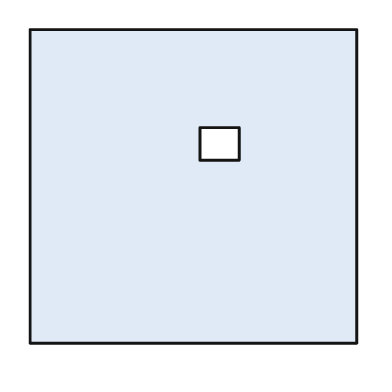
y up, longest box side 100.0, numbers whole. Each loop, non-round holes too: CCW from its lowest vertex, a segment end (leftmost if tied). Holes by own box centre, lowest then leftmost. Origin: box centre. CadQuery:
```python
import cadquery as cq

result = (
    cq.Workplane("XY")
    .moveTo(-50.0, -48.0)
    .lineTo(50.0, -48.0)
    .lineTo(50.0, 48.0)
    .lineTo(-50.0, 48.0)
    .close()
    .moveTo(2.0, 8.0)
    .lineTo(14.0, 8.0)
    .lineTo(14.0, 18.0)
    .lineTo(2.0, 18.0)
    .close()
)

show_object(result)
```